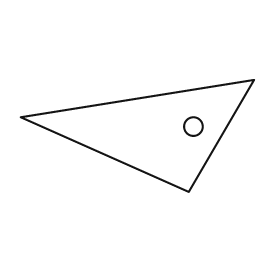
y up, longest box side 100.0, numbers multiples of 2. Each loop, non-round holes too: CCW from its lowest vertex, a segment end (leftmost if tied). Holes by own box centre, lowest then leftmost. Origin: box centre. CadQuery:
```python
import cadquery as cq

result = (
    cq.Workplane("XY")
    .moveTo(22.0, -24.0)
    .lineTo(50.0, 24.0)
    .lineTo(-50.0, 8.0)
    .close()
    .moveTo(24.0, 4.0)
    .circle(4.0)
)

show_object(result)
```